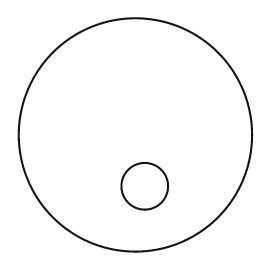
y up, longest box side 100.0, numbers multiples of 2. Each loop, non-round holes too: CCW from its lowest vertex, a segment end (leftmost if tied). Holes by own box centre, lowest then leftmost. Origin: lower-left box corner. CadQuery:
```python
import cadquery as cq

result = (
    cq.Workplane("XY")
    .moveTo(50.0, 50.0)
    .circle(50.0)
    .moveTo(54.0, 28.0)
    .circle(10.0)
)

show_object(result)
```